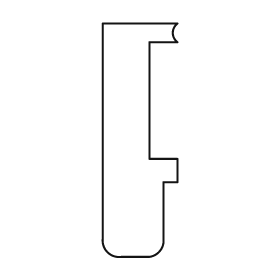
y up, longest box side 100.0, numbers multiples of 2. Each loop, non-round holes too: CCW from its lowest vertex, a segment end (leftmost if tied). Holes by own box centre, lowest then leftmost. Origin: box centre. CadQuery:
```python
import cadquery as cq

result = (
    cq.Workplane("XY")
    .moveTo(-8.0, -50.0)
    .lineTo(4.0, -50.0)
    .threePointArc((8.0, -48.0), (10.0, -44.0))
    .lineTo(10.0, -18.0)
    .lineTo(16.0, -18.0)
    .lineTo(16.0, -8.0)
    .lineTo(4.0, -8.0)
    .lineTo(4.0, 42.0)
    .lineTo(16.0, 42.0)
    .threePointArc((14.0, 46.0), (16.0, 50.0))
    .lineTo(-16.0, 50.0)
    .lineTo(-16.0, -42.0)
    .threePointArc((-14.0, -48.0), (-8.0, -50.0))
    .close()
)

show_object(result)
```